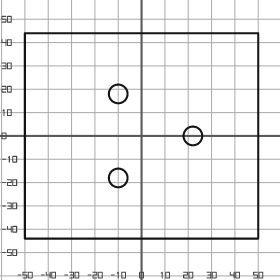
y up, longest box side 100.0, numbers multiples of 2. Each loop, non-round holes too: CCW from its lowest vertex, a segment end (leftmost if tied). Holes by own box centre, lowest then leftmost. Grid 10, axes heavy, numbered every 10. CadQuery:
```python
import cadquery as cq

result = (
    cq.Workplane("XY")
    .moveTo(-50.0, -44.0)
    .lineTo(50.0, -44.0)
    .lineTo(50.0, 44.0)
    .lineTo(-50.0, 44.0)
    .close()
    .moveTo(-10.0, -18.0)
    .circle(4.0)
    .moveTo(22.0, 0.0)
    .circle(4.0)
    .moveTo(-10.0, 18.0)
    .circle(4.0)
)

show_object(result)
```